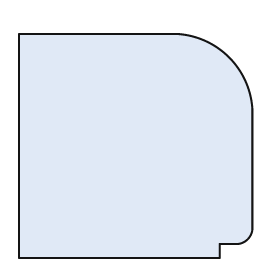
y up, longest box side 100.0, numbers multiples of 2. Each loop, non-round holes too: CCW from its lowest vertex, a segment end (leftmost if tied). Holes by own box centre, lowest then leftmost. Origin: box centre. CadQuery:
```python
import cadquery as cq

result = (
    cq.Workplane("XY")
    .moveTo(-50.0, -48.0)
    .lineTo(36.0, -48.0)
    .lineTo(36.0, -42.0)
    .lineTo(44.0, -42.0)
    .threePointArc((48.0, -40.0), (50.0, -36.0))
    .lineTo(50.0, 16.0)
    .threePointArc((40.0, 38.0), (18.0, 48.0))
    .lineTo(-50.0, 48.0)
    .close()
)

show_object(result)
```